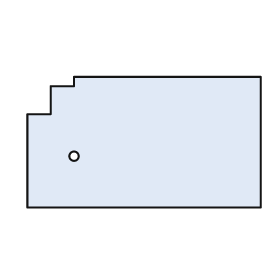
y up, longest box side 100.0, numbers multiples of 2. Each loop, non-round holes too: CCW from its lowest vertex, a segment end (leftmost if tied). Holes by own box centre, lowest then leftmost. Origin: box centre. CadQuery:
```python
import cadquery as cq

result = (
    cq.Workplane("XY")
    .moveTo(-50.0, -28.0)
    .lineTo(50.0, -28.0)
    .lineTo(50.0, 28.0)
    .lineTo(-30.0, 28.0)
    .lineTo(-30.0, 24.0)
    .lineTo(-40.0, 24.0)
    .lineTo(-40.0, 12.0)
    .lineTo(-50.0, 12.0)
    .close()
    .moveTo(-30.0, -6.0)
    .circle(2.0)
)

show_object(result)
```